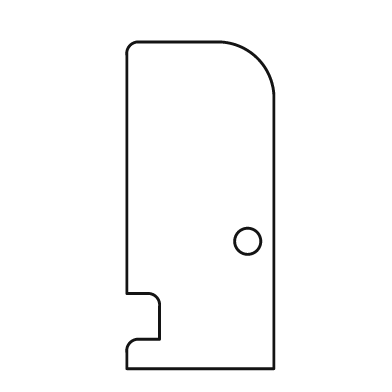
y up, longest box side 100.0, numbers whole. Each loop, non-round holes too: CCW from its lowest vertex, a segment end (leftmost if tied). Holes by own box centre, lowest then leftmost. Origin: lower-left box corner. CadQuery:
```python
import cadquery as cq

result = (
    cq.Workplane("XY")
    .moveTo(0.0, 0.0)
    .lineTo(45.0, 0.0)
    .lineTo(45.0, 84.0)
    .threePointArc((40.0, 95.0), (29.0, 100.0))
    .lineTo(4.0, 100.0)
    .threePointArc((1.0, 99.0), (0.0, 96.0))
    .lineTo(0.0, 23.0)
    .lineTo(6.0, 23.0)
    .threePointArc((9.0, 22.0), (10.0, 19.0))
    .lineTo(10.0, 9.0)
    .lineTo(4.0, 9.0)
    .threePointArc((1.0, 8.0), (0.0, 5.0))
    .close()
    .moveTo(37.0, 39.0)
    .circle(4.0)
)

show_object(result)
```